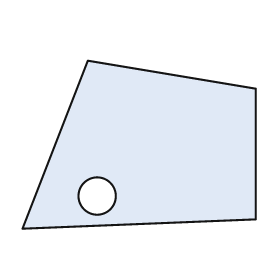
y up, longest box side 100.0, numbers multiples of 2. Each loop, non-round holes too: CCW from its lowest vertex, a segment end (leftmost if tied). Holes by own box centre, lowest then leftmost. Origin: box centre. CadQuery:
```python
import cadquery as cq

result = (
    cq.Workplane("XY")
    .moveTo(-50.0, -36.0)
    .lineTo(50.0, -32.0)
    .lineTo(50.0, 24.0)
    .lineTo(-22.0, 36.0)
    .close()
    .moveTo(-18.0, -22.0)
    .circle(8.0)
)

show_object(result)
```